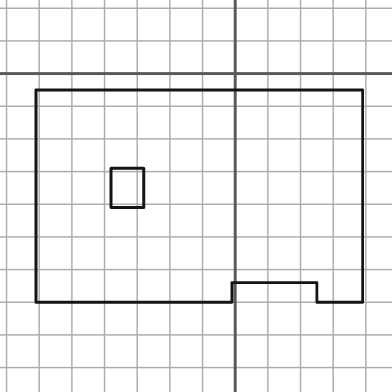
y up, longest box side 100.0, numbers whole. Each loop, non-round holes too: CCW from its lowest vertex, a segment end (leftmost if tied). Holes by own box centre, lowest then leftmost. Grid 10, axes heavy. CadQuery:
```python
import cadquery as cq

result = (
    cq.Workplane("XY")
    .moveTo(-61.0, -70.0)
    .lineTo(-1.0, -70.0)
    .lineTo(-1.0, -64.0)
    .lineTo(25.0, -64.0)
    .lineTo(25.0, -70.0)
    .lineTo(39.0, -70.0)
    .lineTo(39.0, -5.0)
    .lineTo(-61.0, -5.0)
    .close()
    .moveTo(-38.0, -41.0)
    .lineTo(-28.0, -41.0)
    .lineTo(-28.0, -29.0)
    .lineTo(-38.0, -29.0)
    .close()
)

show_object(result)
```